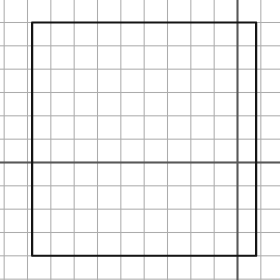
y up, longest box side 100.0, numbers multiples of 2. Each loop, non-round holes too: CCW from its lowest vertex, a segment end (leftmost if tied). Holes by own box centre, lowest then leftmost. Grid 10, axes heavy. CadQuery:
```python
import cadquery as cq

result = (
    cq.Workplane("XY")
    .moveTo(-88.0, -40.0)
    .lineTo(8.0, -40.0)
    .lineTo(8.0, 60.0)
    .lineTo(-88.0, 60.0)
    .close()
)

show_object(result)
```